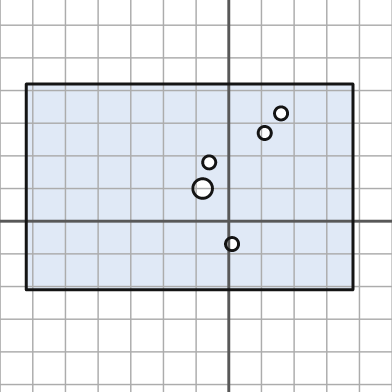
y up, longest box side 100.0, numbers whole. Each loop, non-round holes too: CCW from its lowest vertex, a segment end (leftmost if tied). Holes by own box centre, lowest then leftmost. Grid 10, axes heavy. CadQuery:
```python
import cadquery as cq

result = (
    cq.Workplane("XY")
    .moveTo(-62.0, -21.0)
    .lineTo(38.0, -21.0)
    .lineTo(38.0, 42.0)
    .lineTo(-62.0, 42.0)
    .close()
    .moveTo(1.0, -7.0)
    .circle(2.0)
    .moveTo(-8.0, 10.0)
    .circle(3.0)
    .moveTo(-6.0, 18.0)
    .circle(2.0)
    .moveTo(11.0, 27.0)
    .circle(2.0)
    .moveTo(16.0, 33.0)
    .circle(2.0)
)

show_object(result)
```